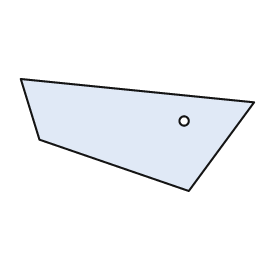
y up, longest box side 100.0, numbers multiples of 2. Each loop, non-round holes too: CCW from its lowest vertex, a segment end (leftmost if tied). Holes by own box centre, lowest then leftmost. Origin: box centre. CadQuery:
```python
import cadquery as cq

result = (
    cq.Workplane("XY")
    .moveTo(22.0, -24.0)
    .lineTo(50.0, 14.0)
    .lineTo(-50.0, 24.0)
    .lineTo(-42.0, -2.0)
    .close()
    .moveTo(20.0, 6.0)
    .circle(2.0)
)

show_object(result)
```